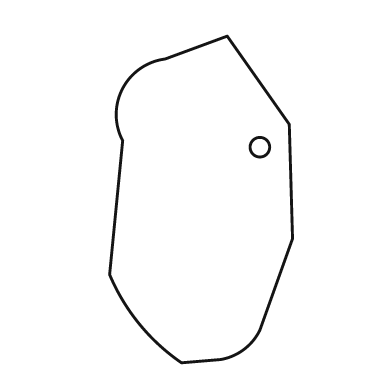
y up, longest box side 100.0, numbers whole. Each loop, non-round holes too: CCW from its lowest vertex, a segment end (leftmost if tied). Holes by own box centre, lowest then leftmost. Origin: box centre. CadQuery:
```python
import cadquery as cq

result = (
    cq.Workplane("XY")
    .moveTo(-6.0, -50.0)
    .lineTo(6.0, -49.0)
    .threePointArc((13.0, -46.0), (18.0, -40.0))
    .lineTo(28.0, -12.0)
    .lineTo(27.0, 23.0)
    .lineTo(8.0, 50.0)
    .lineTo(-11.0, 43.0)
    .threePointArc((-24.0, 34.0), (-24.0, 18.0))
    .lineTo(-28.0, -23.0)
    .threePointArc((-19.0, -38.0), (-6.0, -50.0))
    .close()
    .moveTo(18.0, 16.0)
    .circle(3.0)
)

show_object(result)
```